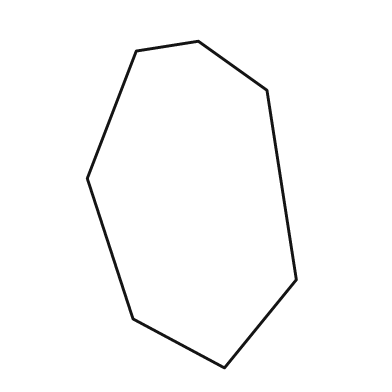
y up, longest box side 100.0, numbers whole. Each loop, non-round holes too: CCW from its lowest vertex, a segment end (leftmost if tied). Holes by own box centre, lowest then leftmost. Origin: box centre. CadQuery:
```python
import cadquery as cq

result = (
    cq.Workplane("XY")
    .moveTo(10.0, -50.0)
    .lineTo(32.0, -23.0)
    .lineTo(23.0, 35.0)
    .lineTo(2.0, 50.0)
    .lineTo(-17.0, 47.0)
    .lineTo(-32.0, 8.0)
    .lineTo(-18.0, -35.0)
    .close()
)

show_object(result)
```